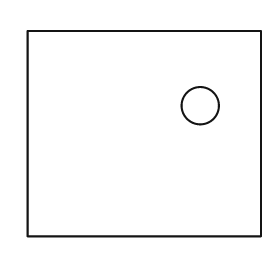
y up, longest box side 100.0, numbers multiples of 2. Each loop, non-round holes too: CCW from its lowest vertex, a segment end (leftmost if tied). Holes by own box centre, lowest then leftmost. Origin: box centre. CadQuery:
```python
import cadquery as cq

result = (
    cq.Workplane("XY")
    .moveTo(-50.0, -44.0)
    .lineTo(50.0, -44.0)
    .lineTo(50.0, 44.0)
    .lineTo(-50.0, 44.0)
    .close()
    .moveTo(24.0, 12.0)
    .circle(8.0)
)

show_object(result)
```